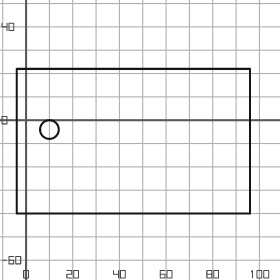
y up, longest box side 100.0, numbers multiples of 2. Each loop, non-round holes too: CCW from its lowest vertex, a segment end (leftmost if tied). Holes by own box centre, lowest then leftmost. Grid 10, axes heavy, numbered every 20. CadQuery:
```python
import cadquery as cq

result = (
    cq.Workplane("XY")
    .moveTo(-4.0, -40.0)
    .lineTo(96.0, -40.0)
    .lineTo(96.0, 22.0)
    .lineTo(-4.0, 22.0)
    .close()
    .moveTo(10.0, -4.0)
    .circle(4.0)
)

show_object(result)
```